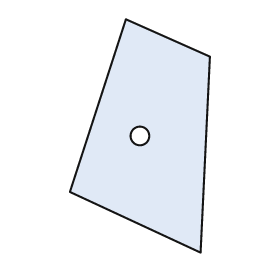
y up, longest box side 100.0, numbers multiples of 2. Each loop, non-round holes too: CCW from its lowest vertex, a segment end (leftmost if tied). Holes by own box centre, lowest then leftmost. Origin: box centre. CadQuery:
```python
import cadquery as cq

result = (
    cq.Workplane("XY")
    .moveTo(26.0, -50.0)
    .lineTo(30.0, 34.0)
    .lineTo(-6.0, 50.0)
    .lineTo(-30.0, -24.0)
    .close()
    .moveTo(0.0, 0.0)
    .circle(4.0)
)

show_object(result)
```